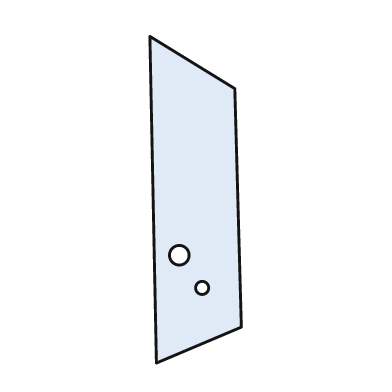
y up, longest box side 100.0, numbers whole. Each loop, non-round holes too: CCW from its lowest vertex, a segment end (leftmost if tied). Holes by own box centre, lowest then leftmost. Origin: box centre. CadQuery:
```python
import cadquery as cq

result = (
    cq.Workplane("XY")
    .moveTo(-12.0, -50.0)
    .lineTo(14.0, -39.0)
    .lineTo(12.0, 34.0)
    .lineTo(-14.0, 50.0)
    .close()
    .moveTo(2.0, -27.0)
    .circle(2.0)
    .moveTo(-5.0, -17.0)
    .circle(3.0)
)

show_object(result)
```